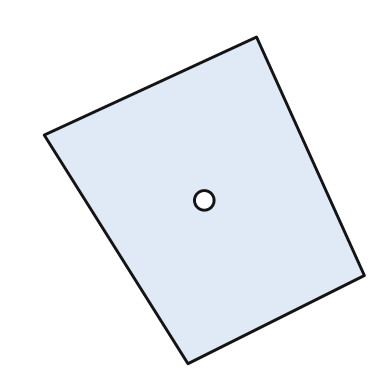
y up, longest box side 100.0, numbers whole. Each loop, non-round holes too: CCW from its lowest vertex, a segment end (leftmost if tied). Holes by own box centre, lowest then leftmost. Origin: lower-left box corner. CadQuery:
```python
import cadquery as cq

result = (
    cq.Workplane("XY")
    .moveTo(44.0, 0.0)
    .lineTo(98.0, 27.0)
    .lineTo(65.0, 100.0)
    .lineTo(0.0, 70.0)
    .close()
    .moveTo(49.0, 50.0)
    .circle(3.0)
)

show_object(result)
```